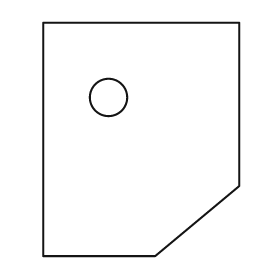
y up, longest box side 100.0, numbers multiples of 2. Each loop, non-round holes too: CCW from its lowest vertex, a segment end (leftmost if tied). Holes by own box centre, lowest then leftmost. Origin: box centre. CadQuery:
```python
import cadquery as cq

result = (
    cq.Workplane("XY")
    .moveTo(-42.0, -50.0)
    .lineTo(6.0, -50.0)
    .lineTo(42.0, -20.0)
    .lineTo(42.0, 50.0)
    .lineTo(-42.0, 50.0)
    .close()
    .moveTo(-14.0, 18.0)
    .circle(8.0)
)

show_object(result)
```